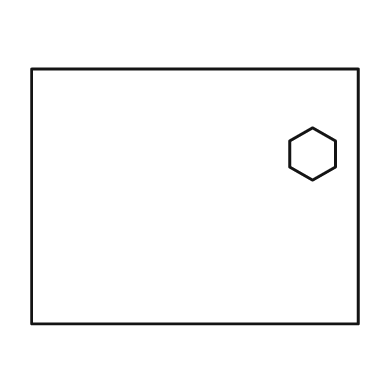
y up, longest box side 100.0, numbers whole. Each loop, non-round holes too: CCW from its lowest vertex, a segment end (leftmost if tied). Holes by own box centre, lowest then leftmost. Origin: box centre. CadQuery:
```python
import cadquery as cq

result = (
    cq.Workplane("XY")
    .moveTo(-50.0, -39.0)
    .lineTo(50.0, -39.0)
    .lineTo(50.0, 39.0)
    .lineTo(-50.0, 39.0)
    .close()
    .moveTo(36.0, 5.0)
    .lineTo(43.0, 9.0)
    .lineTo(43.0, 17.0)
    .lineTo(36.0, 21.0)
    .lineTo(29.0, 17.0)
    .lineTo(29.0, 9.0)
    .close()
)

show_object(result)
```